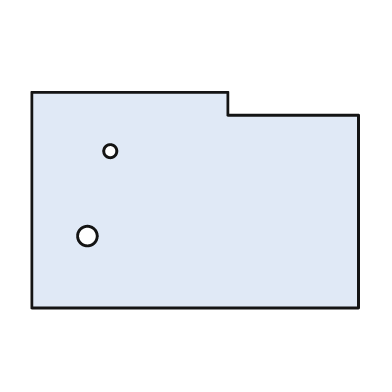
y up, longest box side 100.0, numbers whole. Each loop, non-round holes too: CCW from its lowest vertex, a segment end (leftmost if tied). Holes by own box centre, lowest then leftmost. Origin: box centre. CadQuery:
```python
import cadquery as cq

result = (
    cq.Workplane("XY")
    .moveTo(-50.0, -33.0)
    .lineTo(50.0, -33.0)
    .lineTo(50.0, 26.0)
    .lineTo(10.0, 26.0)
    .lineTo(10.0, 33.0)
    .lineTo(-50.0, 33.0)
    .close()
    .moveTo(-33.0, -11.0)
    .circle(3.0)
    .moveTo(-26.0, 15.0)
    .circle(2.0)
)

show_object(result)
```